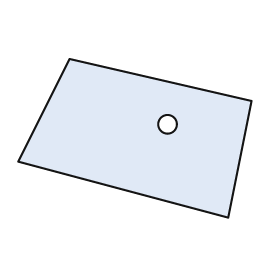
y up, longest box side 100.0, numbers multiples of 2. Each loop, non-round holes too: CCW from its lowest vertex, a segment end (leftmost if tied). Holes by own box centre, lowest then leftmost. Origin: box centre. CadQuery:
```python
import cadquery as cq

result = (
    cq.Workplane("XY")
    .moveTo(40.0, -34.0)
    .lineTo(50.0, 16.0)
    .lineTo(-28.0, 34.0)
    .lineTo(-50.0, -10.0)
    .close()
    .moveTo(14.0, 6.0)
    .circle(4.0)
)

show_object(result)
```